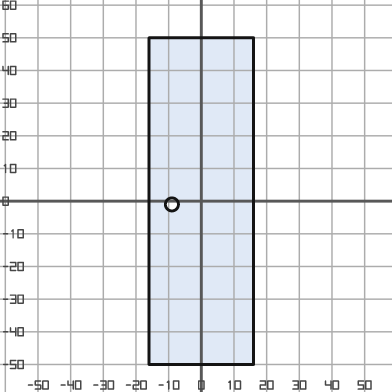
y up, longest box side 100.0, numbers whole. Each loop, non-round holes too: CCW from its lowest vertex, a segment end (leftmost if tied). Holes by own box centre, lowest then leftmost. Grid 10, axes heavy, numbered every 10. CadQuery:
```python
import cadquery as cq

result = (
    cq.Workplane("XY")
    .moveTo(-16.0, -50.0)
    .lineTo(16.0, -50.0)
    .lineTo(16.0, 50.0)
    .lineTo(-16.0, 50.0)
    .close()
    .moveTo(-9.0, -1.0)
    .circle(2.0)
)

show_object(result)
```